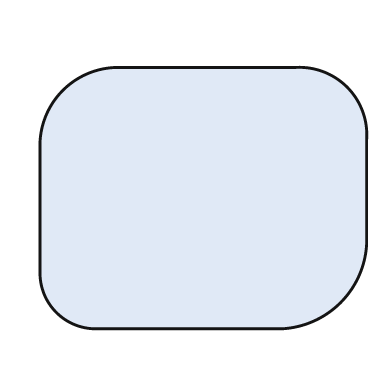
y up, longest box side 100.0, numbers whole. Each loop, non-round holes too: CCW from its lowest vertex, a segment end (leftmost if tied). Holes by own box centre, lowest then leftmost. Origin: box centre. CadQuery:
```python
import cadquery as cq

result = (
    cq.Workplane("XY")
    .moveTo(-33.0, -40.0)
    .lineTo(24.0, -40.0)
    .threePointArc((42.0, -32.0), (50.0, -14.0))
    .lineTo(50.0, 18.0)
    .threePointArc((44.0, 34.0), (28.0, 40.0))
    .lineTo(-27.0, 40.0)
    .threePointArc((-43.0, 33.0), (-50.0, 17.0))
    .lineTo(-50.0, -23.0)
    .threePointArc((-45.0, -35.0), (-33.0, -40.0))
    .close()
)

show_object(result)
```